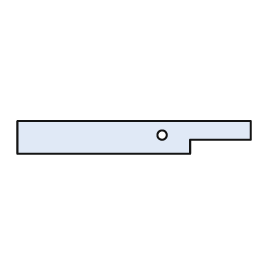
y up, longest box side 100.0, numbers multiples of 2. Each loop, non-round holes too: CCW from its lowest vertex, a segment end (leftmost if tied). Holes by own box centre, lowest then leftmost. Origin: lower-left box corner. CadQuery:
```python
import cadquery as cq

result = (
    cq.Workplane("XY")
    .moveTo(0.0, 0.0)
    .lineTo(74.0, 0.0)
    .lineTo(74.0, 6.0)
    .lineTo(100.0, 6.0)
    .lineTo(100.0, 14.0)
    .lineTo(0.0, 14.0)
    .close()
    .moveTo(62.0, 8.0)
    .circle(2.0)
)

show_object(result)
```